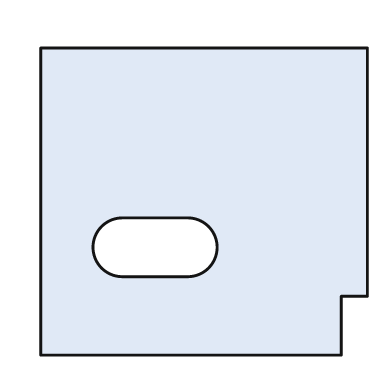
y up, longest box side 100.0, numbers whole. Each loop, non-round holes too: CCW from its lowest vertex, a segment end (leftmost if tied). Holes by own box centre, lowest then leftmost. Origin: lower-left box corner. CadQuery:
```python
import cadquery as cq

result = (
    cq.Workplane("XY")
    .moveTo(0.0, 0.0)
    .lineTo(92.0, 0.0)
    .lineTo(92.0, 18.0)
    .lineTo(100.0, 18.0)
    .lineTo(100.0, 94.0)
    .lineTo(0.0, 94.0)
    .close()
    .moveTo(25.0, 24.0)
    .lineTo(45.0, 24.0)
    .threePointArc((54.0, 33.0), (45.0, 42.0))
    .lineTo(25.0, 42.0)
    .threePointArc((16.0, 33.0), (25.0, 24.0))
    .close()
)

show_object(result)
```